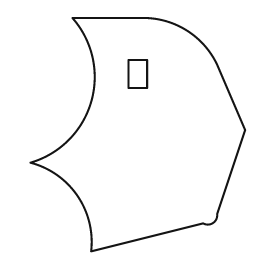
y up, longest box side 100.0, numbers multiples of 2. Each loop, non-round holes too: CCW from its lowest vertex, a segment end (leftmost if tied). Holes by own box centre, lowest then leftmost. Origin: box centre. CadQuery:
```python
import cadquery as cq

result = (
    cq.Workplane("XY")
    .moveTo(-20.0, -50.0)
    .lineTo(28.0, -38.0)
    .threePointArc((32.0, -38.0), (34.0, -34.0))
    .lineTo(46.0, 2.0)
    .lineTo(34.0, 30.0)
    .threePointArc((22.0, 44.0), (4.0, 50.0))
    .lineTo(-28.0, 50.0)
    .threePointArc((-20.0, 14.0), (-46.0, -12.0))
    .threePointArc((-26.0, -26.0), (-20.0, -50.0))
    .close()
    .moveTo(-4.0, 20.0)
    .lineTo(4.0, 20.0)
    .lineTo(4.0, 32.0)
    .lineTo(-4.0, 32.0)
    .close()
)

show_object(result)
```